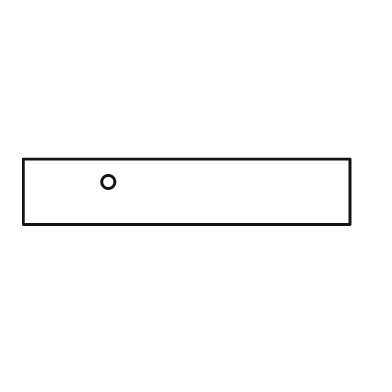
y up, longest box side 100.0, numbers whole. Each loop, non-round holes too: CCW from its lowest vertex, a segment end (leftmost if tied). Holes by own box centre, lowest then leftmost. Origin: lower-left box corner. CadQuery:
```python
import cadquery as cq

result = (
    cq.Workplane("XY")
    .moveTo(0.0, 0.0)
    .lineTo(100.0, 0.0)
    .lineTo(100.0, 20.0)
    .lineTo(0.0, 20.0)
    .close()
    .moveTo(26.0, 13.0)
    .circle(2.0)
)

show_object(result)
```